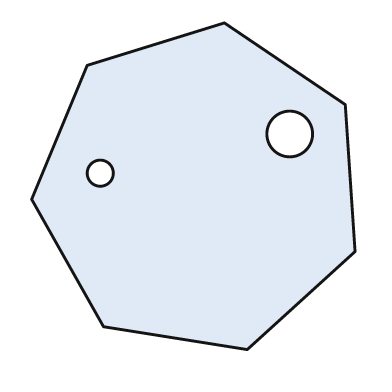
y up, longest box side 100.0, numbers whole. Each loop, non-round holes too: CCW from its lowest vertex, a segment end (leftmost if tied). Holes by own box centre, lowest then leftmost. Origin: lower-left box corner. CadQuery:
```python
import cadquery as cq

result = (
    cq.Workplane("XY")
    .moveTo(66.0, 0.0)
    .lineTo(99.0, 30.0)
    .lineTo(96.0, 75.0)
    .lineTo(59.0, 100.0)
    .lineTo(17.0, 87.0)
    .lineTo(0.0, 46.0)
    .lineTo(22.0, 7.0)
    .close()
    .moveTo(21.0, 54.0)
    .circle(4.0)
    .moveTo(79.0, 66.0)
    .circle(7.0)
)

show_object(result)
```